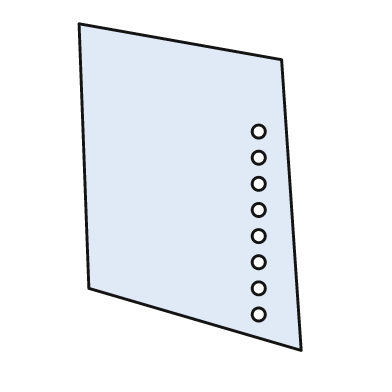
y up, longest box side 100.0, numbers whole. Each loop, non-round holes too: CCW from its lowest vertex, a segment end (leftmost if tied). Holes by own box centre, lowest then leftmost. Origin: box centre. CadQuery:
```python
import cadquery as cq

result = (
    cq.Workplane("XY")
    .moveTo(34.0, -50.0)
    .lineTo(28.0, 39.0)
    .lineTo(-34.0, 50.0)
    .lineTo(-31.0, -31.0)
    .close()
    .moveTo(21.0, -39.0)
    .circle(2.0)
    .moveTo(21.0, -31.0)
    .circle(2.0)
    .moveTo(21.0, -23.0)
    .circle(2.0)
    .moveTo(21.0, -15.0)
    .circle(2.0)
    .moveTo(21.0, -7.0)
    .circle(2.0)
    .moveTo(21.0, 1.0)
    .circle(2.0)
    .moveTo(21.0, 9.0)
    .circle(2.0)
    .moveTo(21.0, 17.0)
    .circle(2.0)
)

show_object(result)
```